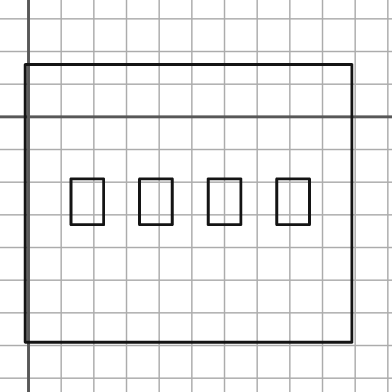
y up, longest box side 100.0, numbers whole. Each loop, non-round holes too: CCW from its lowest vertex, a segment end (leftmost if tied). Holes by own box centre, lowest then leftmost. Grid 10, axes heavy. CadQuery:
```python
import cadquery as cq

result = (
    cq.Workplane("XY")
    .moveTo(-1.0, -69.0)
    .lineTo(99.0, -69.0)
    .lineTo(99.0, 16.0)
    .lineTo(-1.0, 16.0)
    .close()
    .moveTo(13.0, -33.0)
    .lineTo(23.0, -33.0)
    .lineTo(23.0, -19.0)
    .lineTo(13.0, -19.0)
    .close()
    .moveTo(34.0, -33.0)
    .lineTo(44.0, -33.0)
    .lineTo(44.0, -19.0)
    .lineTo(34.0, -19.0)
    .close()
    .moveTo(55.0, -33.0)
    .lineTo(65.0, -33.0)
    .lineTo(65.0, -19.0)
    .lineTo(55.0, -19.0)
    .close()
    .moveTo(76.0, -33.0)
    .lineTo(86.0, -33.0)
    .lineTo(86.0, -19.0)
    .lineTo(76.0, -19.0)
    .close()
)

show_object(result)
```